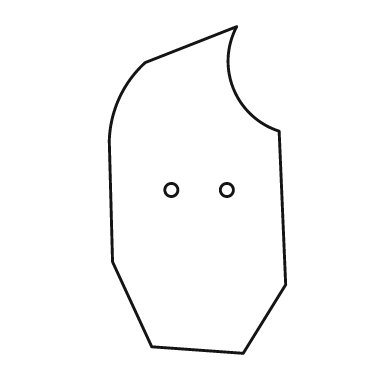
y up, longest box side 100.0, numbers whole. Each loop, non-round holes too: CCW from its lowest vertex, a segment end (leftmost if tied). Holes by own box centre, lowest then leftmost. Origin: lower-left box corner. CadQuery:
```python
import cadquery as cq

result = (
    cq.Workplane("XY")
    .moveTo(41.0, 0.0)
    .lineTo(54.0, 21.0)
    .lineTo(52.0, 68.0)
    .threePointArc((38.0, 81.0), (39.0, 100.0))
    .lineTo(11.0, 89.0)
    .threePointArc((3.0, 78.0), (0.0, 65.0))
    .lineTo(1.0, 28.0)
    .lineTo(13.0, 2.0)
    .close()
    .moveTo(19.0, 50.0)
    .circle(2.0)
    .moveTo(36.0, 50.0)
    .circle(2.0)
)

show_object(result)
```